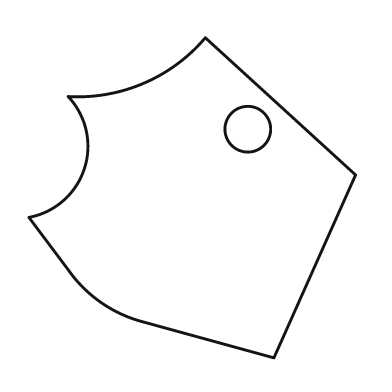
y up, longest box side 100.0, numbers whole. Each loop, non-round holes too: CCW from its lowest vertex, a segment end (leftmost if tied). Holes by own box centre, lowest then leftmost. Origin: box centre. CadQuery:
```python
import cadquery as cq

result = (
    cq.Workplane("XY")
    .moveTo(25.0, -49.0)
    .lineTo(50.0, 7.0)
    .lineTo(4.0, 49.0)
    .threePointArc((-15.0, 35.0), (-38.0, 31.0))
    .threePointArc((-33.0, 9.0), (-50.0, -6.0))
    .lineTo(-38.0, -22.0)
    .threePointArc((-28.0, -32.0), (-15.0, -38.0))
    .close()
    .moveTo(17.0, 21.0)
    .circle(7.0)
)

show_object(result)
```